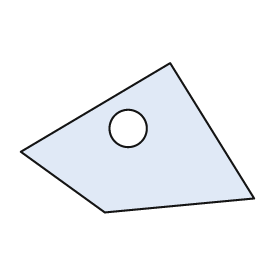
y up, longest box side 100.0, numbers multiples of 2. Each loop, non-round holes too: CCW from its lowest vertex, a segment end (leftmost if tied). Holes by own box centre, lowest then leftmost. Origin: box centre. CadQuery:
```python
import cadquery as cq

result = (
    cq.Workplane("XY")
    .moveTo(-14.0, -32.0)
    .lineTo(50.0, -26.0)
    .lineTo(14.0, 32.0)
    .lineTo(-50.0, -6.0)
    .close()
    .moveTo(-4.0, 4.0)
    .circle(8.0)
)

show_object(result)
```